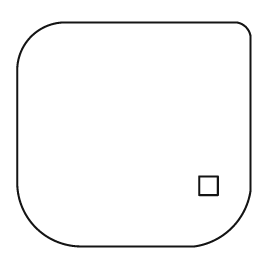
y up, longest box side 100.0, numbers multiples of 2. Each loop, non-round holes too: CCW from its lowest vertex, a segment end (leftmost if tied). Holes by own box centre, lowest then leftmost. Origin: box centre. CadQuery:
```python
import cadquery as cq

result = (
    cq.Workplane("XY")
    .moveTo(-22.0, -48.0)
    .lineTo(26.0, -48.0)
    .threePointArc((42.0, -40.0), (50.0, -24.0))
    .lineTo(50.0, 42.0)
    .threePointArc((48.0, 46.0), (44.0, 48.0))
    .lineTo(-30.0, 48.0)
    .threePointArc((-44.0, 42.0), (-50.0, 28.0))
    .lineTo(-50.0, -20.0)
    .threePointArc((-42.0, -40.0), (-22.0, -48.0))
    .close()
    .moveTo(28.0, -26.0)
    .lineTo(36.0, -26.0)
    .lineTo(36.0, -18.0)
    .lineTo(28.0, -18.0)
    .close()
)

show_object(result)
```